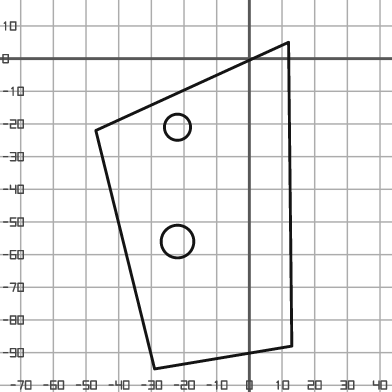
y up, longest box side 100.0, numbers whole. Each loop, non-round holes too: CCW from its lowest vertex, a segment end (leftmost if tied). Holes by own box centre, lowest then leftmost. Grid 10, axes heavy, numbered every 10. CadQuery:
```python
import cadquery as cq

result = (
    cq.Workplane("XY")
    .moveTo(-29.0, -95.0)
    .lineTo(13.0, -88.0)
    .lineTo(12.0, 5.0)
    .lineTo(-47.0, -22.0)
    .close()
    .moveTo(-22.0, -56.0)
    .circle(5.0)
    .moveTo(-22.0, -21.0)
    .circle(4.0)
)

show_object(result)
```